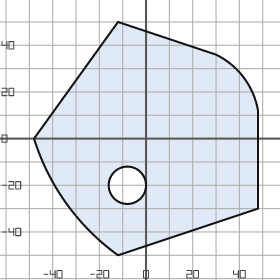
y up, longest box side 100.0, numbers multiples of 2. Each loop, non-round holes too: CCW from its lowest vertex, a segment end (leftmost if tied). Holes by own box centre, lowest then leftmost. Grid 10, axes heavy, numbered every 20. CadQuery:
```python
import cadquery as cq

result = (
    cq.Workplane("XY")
    .moveTo(-12.0, -50.0)
    .lineTo(48.0, -30.0)
    .lineTo(48.0, 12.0)
    .threePointArc((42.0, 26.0), (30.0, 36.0))
    .lineTo(-12.0, 50.0)
    .lineTo(-48.0, 0.0)
    .threePointArc((-34.0, -28.0), (-12.0, -50.0))
    .close()
    .moveTo(-8.0, -20.0)
    .circle(8.0)
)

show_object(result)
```